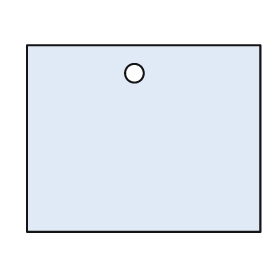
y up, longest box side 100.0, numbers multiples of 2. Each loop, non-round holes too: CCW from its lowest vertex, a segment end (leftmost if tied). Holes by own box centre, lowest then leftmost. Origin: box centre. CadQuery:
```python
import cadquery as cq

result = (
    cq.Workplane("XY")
    .moveTo(-50.0, -40.0)
    .lineTo(50.0, -40.0)
    .lineTo(50.0, 40.0)
    .lineTo(-50.0, 40.0)
    .close()
    .moveTo(-4.0, 28.0)
    .circle(4.0)
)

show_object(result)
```